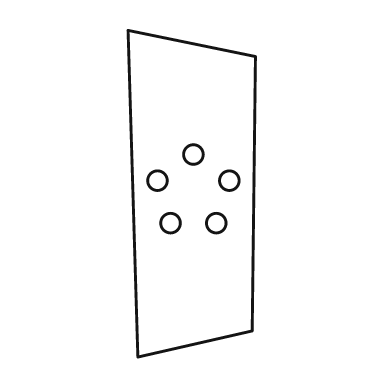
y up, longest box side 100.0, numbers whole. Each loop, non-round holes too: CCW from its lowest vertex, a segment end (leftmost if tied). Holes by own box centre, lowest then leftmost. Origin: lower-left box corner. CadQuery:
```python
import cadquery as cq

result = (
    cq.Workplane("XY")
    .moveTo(3.0, 0.0)
    .lineTo(38.0, 8.0)
    .lineTo(39.0, 92.0)
    .lineTo(0.0, 100.0)
    .close()
    .moveTo(13.0, 41.0)
    .circle(3.0)
    .moveTo(27.0, 41.0)
    .circle(3.0)
    .moveTo(9.0, 54.0)
    .circle(3.0)
    .moveTo(31.0, 54.0)
    .circle(3.0)
    .moveTo(20.0, 62.0)
    .circle(3.0)
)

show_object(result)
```